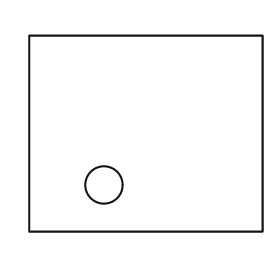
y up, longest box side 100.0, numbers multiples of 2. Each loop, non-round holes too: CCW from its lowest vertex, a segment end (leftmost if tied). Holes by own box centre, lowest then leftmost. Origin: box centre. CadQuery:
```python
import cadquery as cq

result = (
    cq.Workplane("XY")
    .moveTo(-50.0, -42.0)
    .lineTo(50.0, -42.0)
    .lineTo(50.0, 42.0)
    .lineTo(-50.0, 42.0)
    .close()
    .moveTo(-18.0, -22.0)
    .circle(8.0)
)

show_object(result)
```